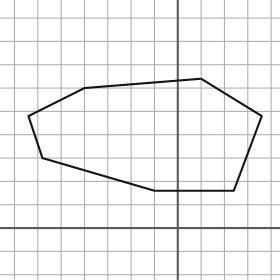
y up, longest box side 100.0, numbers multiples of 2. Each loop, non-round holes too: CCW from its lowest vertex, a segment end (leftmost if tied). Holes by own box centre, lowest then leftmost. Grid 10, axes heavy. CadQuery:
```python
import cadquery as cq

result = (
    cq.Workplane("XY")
    .moveTo(-10.0, 16.0)
    .lineTo(24.0, 16.0)
    .lineTo(36.0, 48.0)
    .lineTo(10.0, 64.0)
    .lineTo(-40.0, 60.0)
    .lineTo(-64.0, 48.0)
    .lineTo(-58.0, 30.0)
    .close()
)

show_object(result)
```